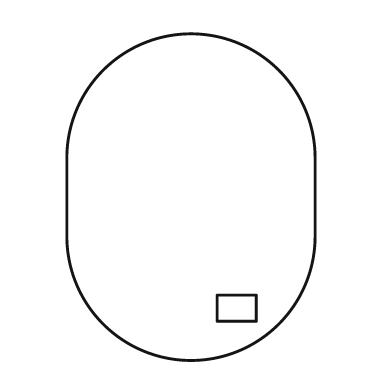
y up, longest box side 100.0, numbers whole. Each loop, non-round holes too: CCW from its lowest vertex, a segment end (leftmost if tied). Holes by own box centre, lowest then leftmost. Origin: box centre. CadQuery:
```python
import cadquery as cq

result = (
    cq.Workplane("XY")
    .moveTo(-38.0, -12.0)
    .threePointArc((0.0, -50.0), (38.0, -12.0))
    .lineTo(38.0, 12.0)
    .threePointArc((0.0, 50.0), (-38.0, 12.0))
    .close()
    .moveTo(8.0, -38.0)
    .lineTo(20.0, -38.0)
    .lineTo(20.0, -30.0)
    .lineTo(8.0, -30.0)
    .close()
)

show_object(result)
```